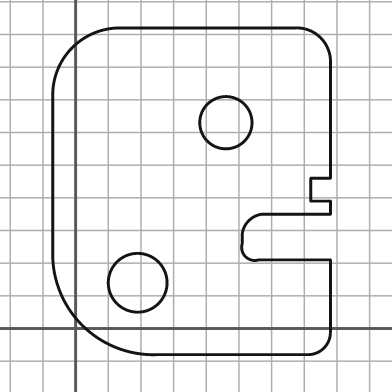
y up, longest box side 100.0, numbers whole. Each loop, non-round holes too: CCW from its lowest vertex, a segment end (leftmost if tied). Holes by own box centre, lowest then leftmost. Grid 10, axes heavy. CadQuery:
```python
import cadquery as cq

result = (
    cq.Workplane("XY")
    .moveTo(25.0, -8.0)
    .lineTo(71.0, -8.0)
    .threePointArc((76.0, -6.0), (78.0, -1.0))
    .lineTo(78.0, 21.0)
    .lineTo(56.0, 21.0)
    .threePointArc((52.0, 22.0), (51.0, 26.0))
    .lineTo(51.0, 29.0)
    .threePointArc((53.0, 33.0), (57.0, 35.0))
    .lineTo(78.0, 35.0)
    .lineTo(78.0, 39.0)
    .lineTo(72.0, 39.0)
    .lineTo(72.0, 46.0)
    .lineTo(78.0, 46.0)
    .lineTo(78.0, 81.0)
    .threePointArc((75.0, 89.0), (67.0, 92.0))
    .lineTo(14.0, 92.0)
    .threePointArc((-1.0, 86.0), (-7.0, 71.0))
    .lineTo(-7.0, 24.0)
    .threePointArc((2.0, 1.0), (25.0, -8.0))
    .close()
    .moveTo(19.0, 14.0)
    .circle(9.0)
    .moveTo(46.0, 63.0)
    .circle(8.0)
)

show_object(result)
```